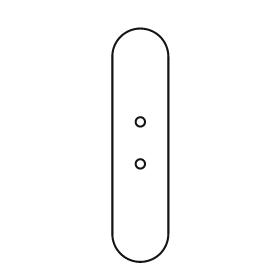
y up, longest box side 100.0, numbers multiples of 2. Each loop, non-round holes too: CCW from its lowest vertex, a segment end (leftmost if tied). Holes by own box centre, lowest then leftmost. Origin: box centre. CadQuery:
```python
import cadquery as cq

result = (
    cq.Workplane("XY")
    .moveTo(-12.0, -38.0)
    .threePointArc((0.0, -50.0), (12.0, -38.0))
    .lineTo(12.0, 38.0)
    .threePointArc((0.0, 50.0), (-12.0, 38.0))
    .close()
    .moveTo(0.0, -8.0)
    .circle(2.0)
    .moveTo(0.0, 10.0)
    .circle(2.0)
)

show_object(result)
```